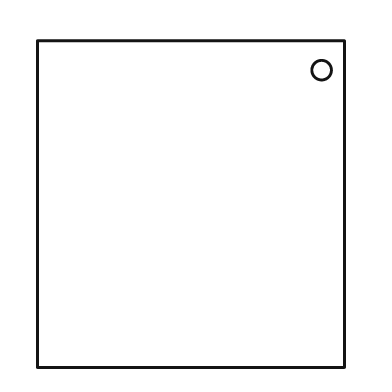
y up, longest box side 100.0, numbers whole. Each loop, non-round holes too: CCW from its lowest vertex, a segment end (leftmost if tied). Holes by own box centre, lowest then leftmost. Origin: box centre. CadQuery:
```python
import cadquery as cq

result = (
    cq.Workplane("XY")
    .moveTo(-47.0, -50.0)
    .lineTo(47.0, -50.0)
    .lineTo(47.0, 50.0)
    .lineTo(-47.0, 50.0)
    .close()
    .moveTo(40.0, 41.0)
    .circle(3.0)
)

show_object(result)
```